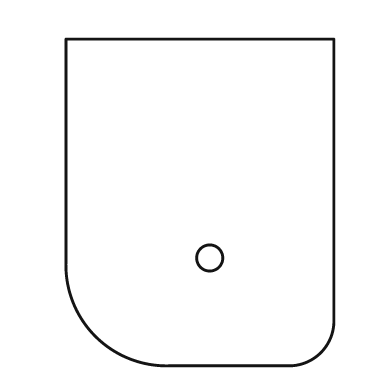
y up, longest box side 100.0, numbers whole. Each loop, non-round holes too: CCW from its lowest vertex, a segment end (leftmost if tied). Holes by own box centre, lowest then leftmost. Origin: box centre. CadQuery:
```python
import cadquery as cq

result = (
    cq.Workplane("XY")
    .moveTo(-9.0, -50.0)
    .lineTo(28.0, -50.0)
    .threePointArc((37.0, -46.0), (41.0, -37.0))
    .lineTo(41.0, 50.0)
    .lineTo(-41.0, 50.0)
    .lineTo(-41.0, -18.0)
    .threePointArc((-32.0, -41.0), (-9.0, -50.0))
    .close()
    .moveTo(3.0, -17.0)
    .circle(4.0)
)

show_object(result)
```